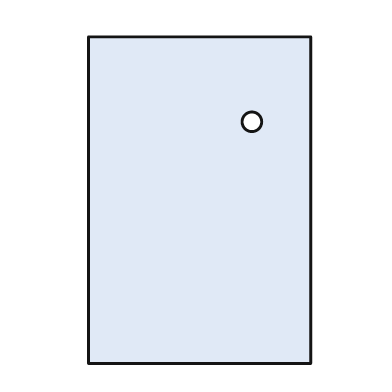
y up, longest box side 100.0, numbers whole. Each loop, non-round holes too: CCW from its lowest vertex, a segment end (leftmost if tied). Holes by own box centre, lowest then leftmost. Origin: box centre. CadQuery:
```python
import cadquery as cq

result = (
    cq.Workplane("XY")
    .moveTo(-34.0, -50.0)
    .lineTo(34.0, -50.0)
    .lineTo(34.0, 50.0)
    .lineTo(-34.0, 50.0)
    .close()
    .moveTo(16.0, 24.0)
    .circle(3.0)
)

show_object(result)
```